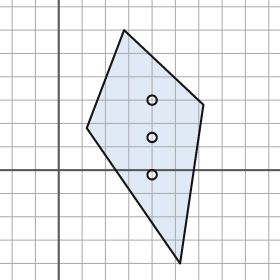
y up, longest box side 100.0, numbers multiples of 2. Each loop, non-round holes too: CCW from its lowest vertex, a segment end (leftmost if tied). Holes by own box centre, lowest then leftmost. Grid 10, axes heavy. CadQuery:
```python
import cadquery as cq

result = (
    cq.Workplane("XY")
    .moveTo(52.0, -40.0)
    .lineTo(62.0, 28.0)
    .lineTo(28.0, 60.0)
    .lineTo(12.0, 18.0)
    .close()
    .moveTo(40.0, -2.0)
    .circle(2.0)
    .moveTo(40.0, 14.0)
    .circle(2.0)
    .moveTo(40.0, 30.0)
    .circle(2.0)
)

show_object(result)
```